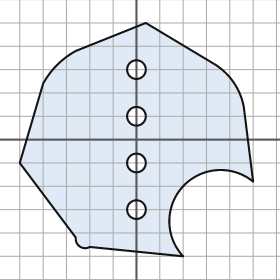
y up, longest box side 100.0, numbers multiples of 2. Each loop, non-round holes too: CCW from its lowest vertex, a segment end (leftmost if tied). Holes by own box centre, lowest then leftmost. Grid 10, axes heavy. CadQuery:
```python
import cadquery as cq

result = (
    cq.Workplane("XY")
    .moveTo(20.0, -50.0)
    .threePointArc((20.0, -20.0), (50.0, -18.0))
    .lineTo(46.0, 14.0)
    .threePointArc((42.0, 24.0), (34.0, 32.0))
    .lineTo(4.0, 50.0)
    .lineTo(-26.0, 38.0)
    .threePointArc((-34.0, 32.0), (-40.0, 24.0))
    .lineTo(-50.0, -10.0)
    .lineTo(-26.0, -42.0)
    .threePointArc((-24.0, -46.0), (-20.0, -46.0))
    .close()
    .moveTo(0.0, -30.0)
    .circle(4.0)
    .moveTo(0.0, -10.0)
    .circle(4.0)
    .moveTo(0.0, 10.0)
    .circle(4.0)
    .moveTo(0.0, 30.0)
    .circle(4.0)
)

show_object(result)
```